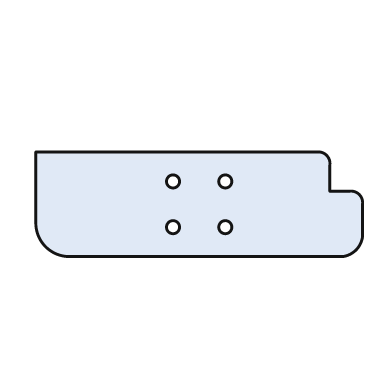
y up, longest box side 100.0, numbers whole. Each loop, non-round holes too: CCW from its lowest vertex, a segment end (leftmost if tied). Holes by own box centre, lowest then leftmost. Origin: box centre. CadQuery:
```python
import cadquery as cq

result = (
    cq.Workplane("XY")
    .moveTo(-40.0, -16.0)
    .lineTo(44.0, -16.0)
    .threePointArc((48.0, -14.0), (50.0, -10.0))
    .lineTo(50.0, 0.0)
    .threePointArc((49.0, 3.0), (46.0, 4.0))
    .lineTo(40.0, 4.0)
    .lineTo(40.0, 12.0)
    .threePointArc((39.0, 15.0), (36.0, 16.0))
    .lineTo(-50.0, 16.0)
    .lineTo(-50.0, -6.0)
    .threePointArc((-47.0, -13.0), (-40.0, -16.0))
    .close()
    .moveTo(-8.0, -7.0)
    .circle(2.0)
    .moveTo(8.0, -7.0)
    .circle(2.0)
    .moveTo(-8.0, 7.0)
    .circle(2.0)
    .moveTo(8.0, 7.0)
    .circle(2.0)
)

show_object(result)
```